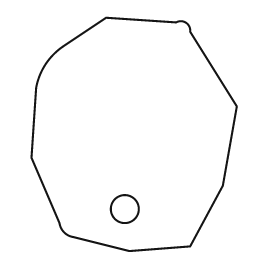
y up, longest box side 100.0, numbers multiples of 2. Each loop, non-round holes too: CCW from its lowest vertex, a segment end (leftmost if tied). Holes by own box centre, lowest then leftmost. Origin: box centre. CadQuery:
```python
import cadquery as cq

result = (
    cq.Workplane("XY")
    .moveTo(-2.0, -50.0)
    .lineTo(24.0, -48.0)
    .lineTo(38.0, -22.0)
    .lineTo(44.0, 12.0)
    .lineTo(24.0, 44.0)
    .threePointArc((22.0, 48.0), (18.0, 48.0))
    .lineTo(-12.0, 50.0)
    .lineTo(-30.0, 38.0)
    .threePointArc((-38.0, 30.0), (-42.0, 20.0))
    .lineTo(-44.0, -10.0)
    .lineTo(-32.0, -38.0)
    .threePointArc((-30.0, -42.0), (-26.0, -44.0))
    .close()
    .moveTo(-4.0, -32.0)
    .circle(6.0)
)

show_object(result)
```